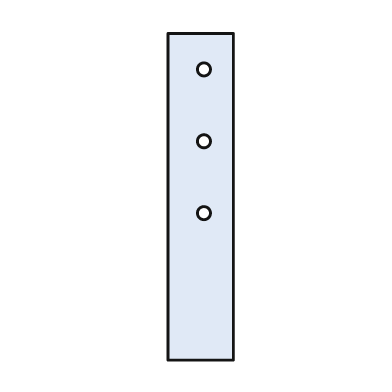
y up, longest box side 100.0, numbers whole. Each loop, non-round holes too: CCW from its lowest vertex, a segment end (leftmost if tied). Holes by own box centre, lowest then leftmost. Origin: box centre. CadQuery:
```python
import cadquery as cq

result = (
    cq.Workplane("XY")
    .moveTo(-10.0, -50.0)
    .lineTo(10.0, -50.0)
    .lineTo(10.0, 50.0)
    .lineTo(-10.0, 50.0)
    .close()
    .moveTo(1.0, -5.0)
    .circle(2.0)
    .moveTo(1.0, 17.0)
    .circle(2.0)
    .moveTo(1.0, 39.0)
    .circle(2.0)
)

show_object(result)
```